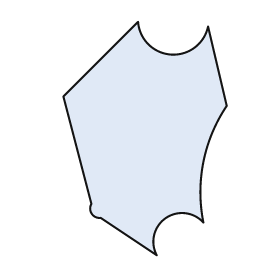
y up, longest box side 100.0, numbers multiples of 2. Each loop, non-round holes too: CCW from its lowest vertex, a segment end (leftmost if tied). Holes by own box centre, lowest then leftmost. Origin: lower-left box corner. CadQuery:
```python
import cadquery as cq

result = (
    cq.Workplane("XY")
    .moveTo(40.0, 0.0)
    .threePointArc((44.0, 16.0), (60.0, 14.0))
    .threePointArc((60.0, 40.0), (70.0, 64.0))
    .lineTo(62.0, 98.0)
    .threePointArc((46.0, 86.0), (32.0, 100.0))
    .lineTo(0.0, 68.0)
    .lineTo(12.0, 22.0)
    .threePointArc((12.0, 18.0), (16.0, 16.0))
    .close()
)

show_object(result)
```